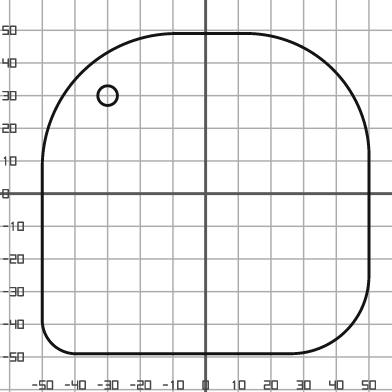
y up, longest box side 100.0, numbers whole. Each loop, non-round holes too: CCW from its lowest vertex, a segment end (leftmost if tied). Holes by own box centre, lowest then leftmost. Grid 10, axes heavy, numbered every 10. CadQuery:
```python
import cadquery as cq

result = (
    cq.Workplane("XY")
    .moveTo(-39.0, -49.0)
    .lineTo(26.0, -49.0)
    .threePointArc((43.0, -42.0), (50.0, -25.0))
    .lineTo(50.0, 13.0)
    .threePointArc((39.0, 38.0), (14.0, 49.0))
    .lineTo(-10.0, 49.0)
    .threePointArc((-38.0, 37.0), (-50.0, 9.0))
    .lineTo(-50.0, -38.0)
    .threePointArc((-47.0, -46.0), (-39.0, -49.0))
    .close()
    .moveTo(-30.0, 30.0)
    .circle(3.0)
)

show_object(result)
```